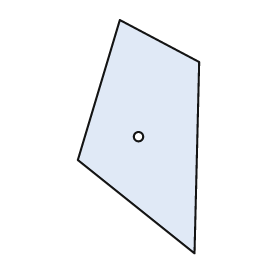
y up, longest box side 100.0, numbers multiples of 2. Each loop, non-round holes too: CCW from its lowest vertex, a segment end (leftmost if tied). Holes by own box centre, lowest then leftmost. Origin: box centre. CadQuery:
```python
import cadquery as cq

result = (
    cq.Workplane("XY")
    .moveTo(24.0, -50.0)
    .lineTo(26.0, 32.0)
    .lineTo(-8.0, 50.0)
    .lineTo(-26.0, -10.0)
    .close()
    .moveTo(0.0, 0.0)
    .circle(2.0)
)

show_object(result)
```